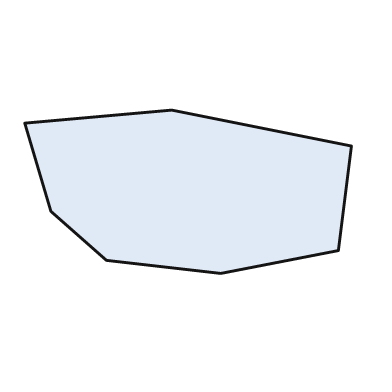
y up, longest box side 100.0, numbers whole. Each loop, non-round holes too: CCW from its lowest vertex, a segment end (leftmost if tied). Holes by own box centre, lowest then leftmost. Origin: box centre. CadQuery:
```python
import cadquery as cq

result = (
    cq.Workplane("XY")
    .moveTo(10.0, -25.0)
    .lineTo(46.0, -18.0)
    .lineTo(50.0, 14.0)
    .lineTo(-5.0, 25.0)
    .lineTo(-50.0, 21.0)
    .lineTo(-42.0, -6.0)
    .lineTo(-25.0, -21.0)
    .close()
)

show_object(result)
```